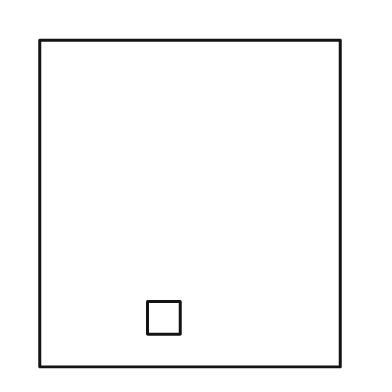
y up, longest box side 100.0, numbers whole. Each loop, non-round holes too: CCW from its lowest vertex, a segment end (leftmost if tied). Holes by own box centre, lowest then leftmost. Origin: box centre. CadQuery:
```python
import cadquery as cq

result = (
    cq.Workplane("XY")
    .moveTo(-46.0, -50.0)
    .lineTo(46.0, -50.0)
    .lineTo(46.0, 50.0)
    .lineTo(-46.0, 50.0)
    .close()
    .moveTo(-13.0, -40.0)
    .lineTo(-3.0, -40.0)
    .lineTo(-3.0, -30.0)
    .lineTo(-13.0, -30.0)
    .close()
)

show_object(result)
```